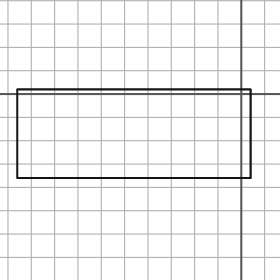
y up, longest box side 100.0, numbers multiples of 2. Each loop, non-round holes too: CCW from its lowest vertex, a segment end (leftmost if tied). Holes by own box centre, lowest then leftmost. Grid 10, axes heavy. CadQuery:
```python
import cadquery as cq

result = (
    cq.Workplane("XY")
    .moveTo(-96.0, -36.0)
    .lineTo(4.0, -36.0)
    .lineTo(4.0, 2.0)
    .lineTo(-96.0, 2.0)
    .close()
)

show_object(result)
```